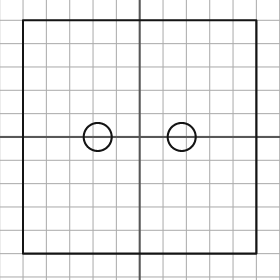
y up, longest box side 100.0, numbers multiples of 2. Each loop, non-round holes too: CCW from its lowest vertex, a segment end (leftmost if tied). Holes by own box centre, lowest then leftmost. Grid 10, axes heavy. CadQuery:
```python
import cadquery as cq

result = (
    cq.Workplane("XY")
    .moveTo(-50.0, -50.0)
    .lineTo(50.0, -50.0)
    .lineTo(50.0, 50.0)
    .lineTo(-50.0, 50.0)
    .close()
    .moveTo(-18.0, 0.0)
    .circle(6.0)
    .moveTo(18.0, 0.0)
    .circle(6.0)
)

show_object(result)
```